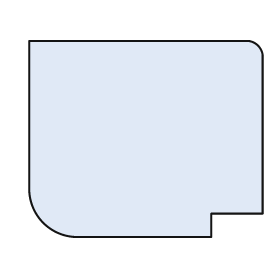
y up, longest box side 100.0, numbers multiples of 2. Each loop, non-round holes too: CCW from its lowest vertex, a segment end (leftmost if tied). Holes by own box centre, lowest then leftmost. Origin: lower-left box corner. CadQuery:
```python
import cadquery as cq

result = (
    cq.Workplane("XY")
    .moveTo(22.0, 0.0)
    .lineTo(78.0, 0.0)
    .lineTo(78.0, 10.0)
    .lineTo(100.0, 10.0)
    .lineTo(100.0, 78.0)
    .threePointArc((98.0, 82.0), (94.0, 84.0))
    .lineTo(0.0, 84.0)
    .lineTo(0.0, 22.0)
    .threePointArc((6.0, 6.0), (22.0, 0.0))
    .close()
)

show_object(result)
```